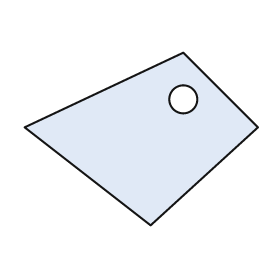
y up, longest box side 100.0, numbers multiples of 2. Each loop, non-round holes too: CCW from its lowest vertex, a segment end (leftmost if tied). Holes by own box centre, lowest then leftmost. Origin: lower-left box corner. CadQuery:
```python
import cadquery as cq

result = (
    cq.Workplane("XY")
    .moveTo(54.0, 0.0)
    .lineTo(100.0, 42.0)
    .lineTo(68.0, 74.0)
    .lineTo(0.0, 42.0)
    .close()
    .moveTo(68.0, 54.0)
    .circle(6.0)
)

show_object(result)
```